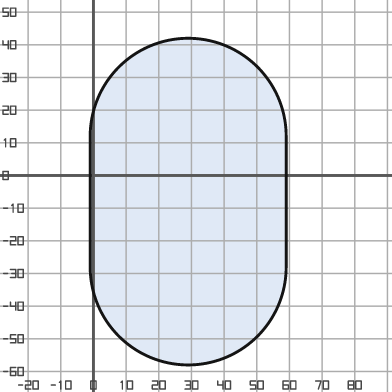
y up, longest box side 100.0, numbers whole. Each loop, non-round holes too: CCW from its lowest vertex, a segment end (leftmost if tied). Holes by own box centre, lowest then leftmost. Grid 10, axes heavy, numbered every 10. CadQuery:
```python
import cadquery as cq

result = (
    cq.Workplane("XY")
    .moveTo(-1.0, -28.0)
    .threePointArc((29.0, -58.0), (59.0, -28.0))
    .lineTo(59.0, 12.0)
    .threePointArc((29.0, 42.0), (-1.0, 12.0))
    .close()
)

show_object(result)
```